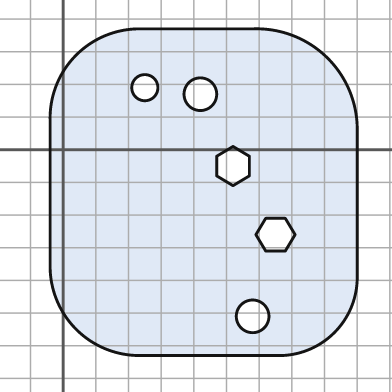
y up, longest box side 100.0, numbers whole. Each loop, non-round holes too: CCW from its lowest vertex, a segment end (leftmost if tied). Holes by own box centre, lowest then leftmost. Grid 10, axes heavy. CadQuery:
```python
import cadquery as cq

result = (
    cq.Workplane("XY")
    .moveTo(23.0, -63.0)
    .lineTo(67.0, -63.0)
    .threePointArc((83.0, -56.0), (90.0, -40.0))
    .lineTo(90.0, 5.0)
    .threePointArc((81.0, 28.0), (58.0, 37.0))
    .lineTo(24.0, 37.0)
    .threePointArc((4.0, 29.0), (-4.0, 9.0))
    .lineTo(-4.0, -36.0)
    .threePointArc((4.0, -55.0), (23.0, -63.0))
    .close()
    .moveTo(58.0, -51.0)
    .circle(5.0)
    .moveTo(62.0, -31.0)
    .lineTo(68.0, -31.0)
    .lineTo(71.0, -26.0)
    .lineTo(68.0, -21.0)
    .lineTo(62.0, -21.0)
    .lineTo(59.0, -26.0)
    .close()
    .moveTo(52.0, -11.0)
    .lineTo(57.0, -8.0)
    .lineTo(57.0, -2.0)
    .lineTo(52.0, 1.0)
    .lineTo(47.0, -2.0)
    .lineTo(47.0, -8.0)
    .close()
    .moveTo(42.0, 17.0)
    .circle(5.0)
    .moveTo(25.0, 19.0)
    .circle(4.0)
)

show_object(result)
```